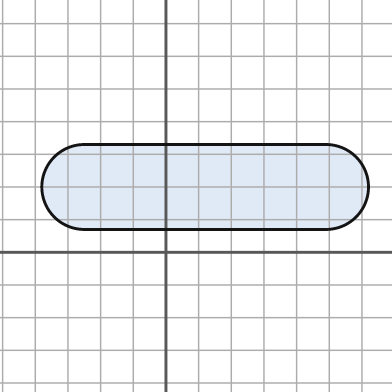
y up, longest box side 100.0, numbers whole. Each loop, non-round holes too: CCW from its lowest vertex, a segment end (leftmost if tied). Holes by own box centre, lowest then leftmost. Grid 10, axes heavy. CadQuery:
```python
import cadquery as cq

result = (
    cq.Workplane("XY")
    .moveTo(-25.0, 7.0)
    .lineTo(49.0, 7.0)
    .threePointArc((62.0, 20.0), (49.0, 33.0))
    .lineTo(-25.0, 33.0)
    .threePointArc((-38.0, 20.0), (-25.0, 7.0))
    .close()
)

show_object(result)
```